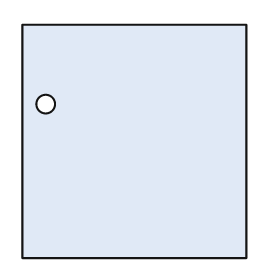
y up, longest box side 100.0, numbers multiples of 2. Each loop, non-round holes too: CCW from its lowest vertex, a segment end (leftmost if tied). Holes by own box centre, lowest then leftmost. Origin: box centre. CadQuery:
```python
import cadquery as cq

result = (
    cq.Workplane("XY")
    .moveTo(-48.0, -50.0)
    .lineTo(48.0, -50.0)
    .lineTo(48.0, 50.0)
    .lineTo(-48.0, 50.0)
    .close()
    .moveTo(-38.0, 16.0)
    .circle(4.0)
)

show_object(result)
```